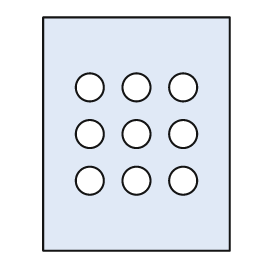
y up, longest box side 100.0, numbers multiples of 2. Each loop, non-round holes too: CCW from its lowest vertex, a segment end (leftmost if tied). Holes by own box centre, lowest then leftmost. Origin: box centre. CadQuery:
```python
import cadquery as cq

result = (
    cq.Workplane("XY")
    .moveTo(-40.0, -50.0)
    .lineTo(40.0, -50.0)
    .lineTo(40.0, 50.0)
    .lineTo(-40.0, 50.0)
    .close()
    .moveTo(-20.0, -20.0)
    .circle(6.0)
    .moveTo(0.0, -20.0)
    .circle(6.0)
    .moveTo(20.0, -20.0)
    .circle(6.0)
    .moveTo(-20.0, 0.0)
    .circle(6.0)
    .moveTo(0.0, 0.0)
    .circle(6.0)
    .moveTo(20.0, 0.0)
    .circle(6.0)
    .moveTo(-20.0, 20.0)
    .circle(6.0)
    .moveTo(0.0, 20.0)
    .circle(6.0)
    .moveTo(20.0, 20.0)
    .circle(6.0)
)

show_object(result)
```